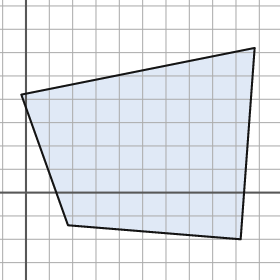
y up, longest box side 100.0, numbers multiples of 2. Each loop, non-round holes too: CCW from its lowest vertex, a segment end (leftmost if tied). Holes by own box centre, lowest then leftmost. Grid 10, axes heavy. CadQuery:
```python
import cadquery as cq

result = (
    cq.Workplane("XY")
    .moveTo(92.0, -20.0)
    .lineTo(98.0, 62.0)
    .lineTo(-2.0, 42.0)
    .lineTo(18.0, -14.0)
    .close()
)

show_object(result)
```